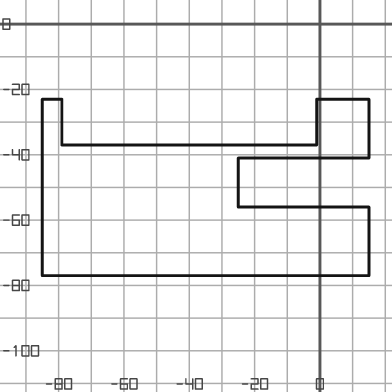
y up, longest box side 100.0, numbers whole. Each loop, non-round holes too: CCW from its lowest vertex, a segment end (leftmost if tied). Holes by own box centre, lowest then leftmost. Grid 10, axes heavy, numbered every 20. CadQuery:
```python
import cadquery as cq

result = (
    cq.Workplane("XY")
    .moveTo(-85.0, -77.0)
    .lineTo(15.0, -77.0)
    .lineTo(15.0, -56.0)
    .lineTo(-25.0, -56.0)
    .lineTo(-25.0, -41.0)
    .lineTo(15.0, -41.0)
    .lineTo(15.0, -23.0)
    .lineTo(-1.0, -23.0)
    .lineTo(-1.0, -37.0)
    .lineTo(-79.0, -37.0)
    .lineTo(-79.0, -23.0)
    .lineTo(-85.0, -23.0)
    .close()
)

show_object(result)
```